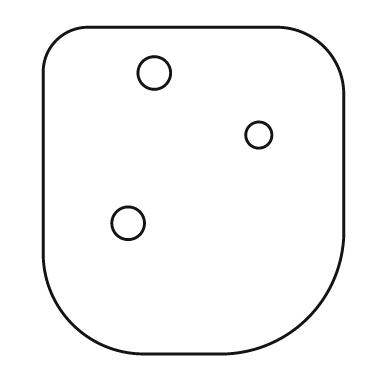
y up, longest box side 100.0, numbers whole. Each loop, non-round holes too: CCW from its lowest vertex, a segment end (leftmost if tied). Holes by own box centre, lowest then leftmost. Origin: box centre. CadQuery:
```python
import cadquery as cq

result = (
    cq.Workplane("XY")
    .moveTo(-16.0, -50.0)
    .lineTo(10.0, -50.0)
    .threePointArc((35.0, -39.0), (46.0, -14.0))
    .lineTo(46.0, 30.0)
    .threePointArc((40.0, 44.0), (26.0, 50.0))
    .lineTo(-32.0, 50.0)
    .threePointArc((-42.0, 46.0), (-46.0, 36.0))
    .lineTo(-46.0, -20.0)
    .threePointArc((-37.0, -41.0), (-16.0, -50.0))
    .close()
    .moveTo(-20.0, -10.0)
    .circle(5.0)
    .moveTo(20.0, 17.0)
    .circle(4.0)
    .moveTo(-12.0, 36.0)
    .circle(5.0)
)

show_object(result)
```